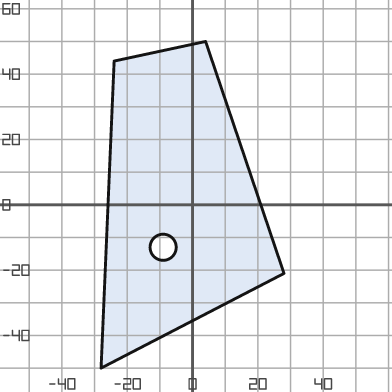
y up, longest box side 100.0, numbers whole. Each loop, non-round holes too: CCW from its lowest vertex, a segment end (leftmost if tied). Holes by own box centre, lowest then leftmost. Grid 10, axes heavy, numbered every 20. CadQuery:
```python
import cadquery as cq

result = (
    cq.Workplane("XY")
    .moveTo(-28.0, -50.0)
    .lineTo(28.0, -21.0)
    .lineTo(4.0, 50.0)
    .lineTo(-24.0, 44.0)
    .close()
    .moveTo(-9.0, -13.0)
    .circle(4.0)
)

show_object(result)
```